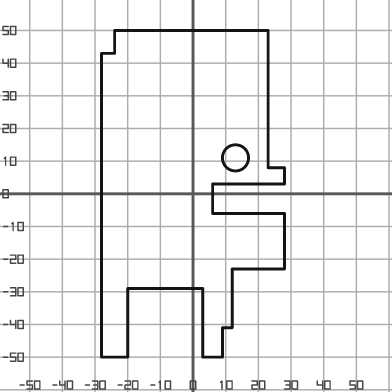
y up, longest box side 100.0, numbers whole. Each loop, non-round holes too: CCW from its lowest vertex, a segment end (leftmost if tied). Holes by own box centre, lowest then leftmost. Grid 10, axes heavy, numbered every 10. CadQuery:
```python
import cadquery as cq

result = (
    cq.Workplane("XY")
    .moveTo(-28.0, -50.0)
    .lineTo(-20.0, -50.0)
    .lineTo(-20.0, -29.0)
    .lineTo(3.0, -29.0)
    .lineTo(3.0, -50.0)
    .lineTo(9.0, -50.0)
    .lineTo(9.0, -41.0)
    .lineTo(12.0, -41.0)
    .lineTo(12.0, -23.0)
    .lineTo(28.0, -23.0)
    .lineTo(28.0, -6.0)
    .lineTo(6.0, -6.0)
    .lineTo(6.0, 3.0)
    .lineTo(28.0, 3.0)
    .lineTo(28.0, 8.0)
    .lineTo(23.0, 8.0)
    .lineTo(23.0, 50.0)
    .lineTo(-24.0, 50.0)
    .lineTo(-24.0, 43.0)
    .lineTo(-28.0, 43.0)
    .close()
    .moveTo(13.0, 11.0)
    .circle(4.0)
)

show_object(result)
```